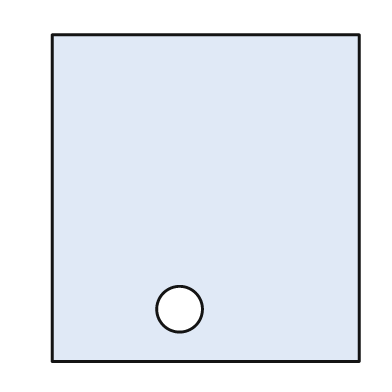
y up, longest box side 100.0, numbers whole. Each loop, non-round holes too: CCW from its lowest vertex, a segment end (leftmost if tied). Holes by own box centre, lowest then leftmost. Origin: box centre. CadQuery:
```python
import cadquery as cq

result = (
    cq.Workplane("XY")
    .moveTo(-47.0, -50.0)
    .lineTo(47.0, -50.0)
    .lineTo(47.0, 50.0)
    .lineTo(-47.0, 50.0)
    .close()
    .moveTo(-8.0, -34.0)
    .circle(7.0)
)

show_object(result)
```